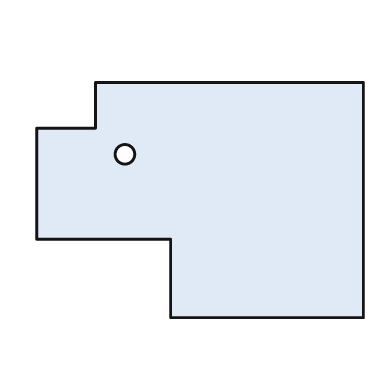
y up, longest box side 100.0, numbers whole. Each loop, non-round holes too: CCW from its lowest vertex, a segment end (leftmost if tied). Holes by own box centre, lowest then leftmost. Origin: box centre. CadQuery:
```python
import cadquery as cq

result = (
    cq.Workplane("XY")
    .moveTo(-9.0, -36.0)
    .lineTo(50.0, -36.0)
    .lineTo(50.0, 36.0)
    .lineTo(-32.0, 36.0)
    .lineTo(-32.0, 22.0)
    .lineTo(-50.0, 22.0)
    .lineTo(-50.0, -12.0)
    .lineTo(-9.0, -12.0)
    .close()
    .moveTo(-23.0, 14.0)
    .circle(3.0)
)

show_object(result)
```